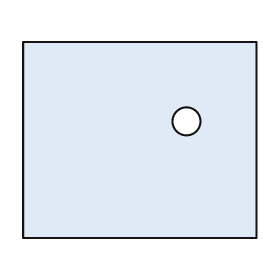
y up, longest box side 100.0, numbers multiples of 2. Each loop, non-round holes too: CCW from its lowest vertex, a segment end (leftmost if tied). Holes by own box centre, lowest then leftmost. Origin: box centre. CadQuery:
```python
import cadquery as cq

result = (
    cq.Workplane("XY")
    .moveTo(-50.0, -42.0)
    .lineTo(50.0, -42.0)
    .lineTo(50.0, 42.0)
    .lineTo(-50.0, 42.0)
    .close()
    .moveTo(20.0, 8.0)
    .circle(6.0)
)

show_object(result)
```